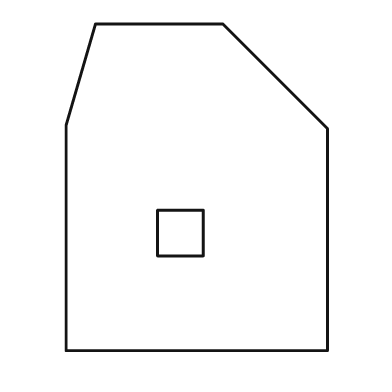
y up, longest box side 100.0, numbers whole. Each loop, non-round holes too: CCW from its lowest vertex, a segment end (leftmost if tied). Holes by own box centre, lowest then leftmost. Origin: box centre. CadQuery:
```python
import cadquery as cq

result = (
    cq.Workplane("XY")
    .moveTo(-40.0, -50.0)
    .lineTo(40.0, -50.0)
    .lineTo(40.0, 18.0)
    .lineTo(8.0, 50.0)
    .lineTo(-31.0, 50.0)
    .lineTo(-40.0, 19.0)
    .close()
    .moveTo(-12.0, -21.0)
    .lineTo(2.0, -21.0)
    .lineTo(2.0, -7.0)
    .lineTo(-12.0, -7.0)
    .close()
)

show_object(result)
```